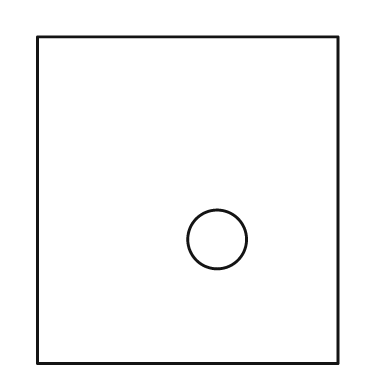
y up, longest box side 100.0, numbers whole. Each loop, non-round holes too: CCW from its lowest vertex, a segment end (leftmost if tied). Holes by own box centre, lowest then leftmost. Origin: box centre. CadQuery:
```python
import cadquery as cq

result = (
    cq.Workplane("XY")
    .moveTo(-46.0, -50.0)
    .lineTo(46.0, -50.0)
    .lineTo(46.0, 50.0)
    .lineTo(-46.0, 50.0)
    .close()
    .moveTo(9.0, -12.0)
    .circle(9.0)
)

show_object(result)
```